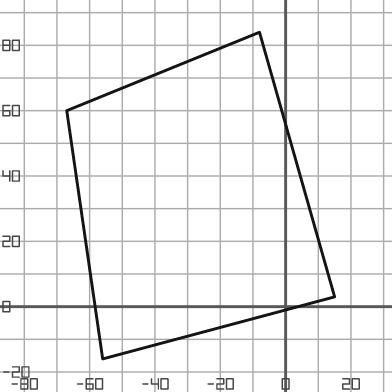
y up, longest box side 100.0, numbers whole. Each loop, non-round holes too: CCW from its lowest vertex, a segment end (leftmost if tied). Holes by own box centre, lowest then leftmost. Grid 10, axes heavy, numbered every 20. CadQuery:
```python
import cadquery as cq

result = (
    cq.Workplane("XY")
    .moveTo(-56.0, -16.0)
    .lineTo(15.0, 3.0)
    .lineTo(-8.0, 84.0)
    .lineTo(-67.0, 60.0)
    .close()
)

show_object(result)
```